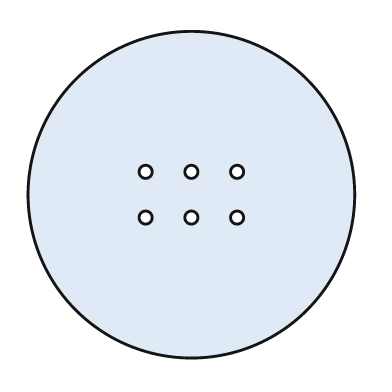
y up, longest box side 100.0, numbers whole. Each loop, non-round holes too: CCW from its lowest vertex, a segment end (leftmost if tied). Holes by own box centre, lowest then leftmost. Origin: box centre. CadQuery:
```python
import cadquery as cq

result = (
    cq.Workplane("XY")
    .moveTo(0.0, 0.0)
    .circle(50.0)
    .moveTo(-14.0, -7.0)
    .circle(2.0)
    .moveTo(0.0, -7.0)
    .circle(2.0)
    .moveTo(14.0, -7.0)
    .circle(2.0)
    .moveTo(-14.0, 7.0)
    .circle(2.0)
    .moveTo(0.0, 7.0)
    .circle(2.0)
    .moveTo(14.0, 7.0)
    .circle(2.0)
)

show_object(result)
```